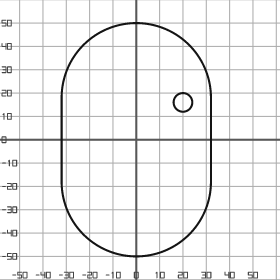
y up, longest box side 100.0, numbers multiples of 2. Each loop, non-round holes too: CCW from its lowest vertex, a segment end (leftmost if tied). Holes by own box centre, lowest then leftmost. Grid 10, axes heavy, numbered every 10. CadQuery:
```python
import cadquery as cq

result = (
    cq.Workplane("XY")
    .moveTo(-32.0, -18.0)
    .threePointArc((0.0, -50.0), (32.0, -18.0))
    .lineTo(32.0, 18.0)
    .threePointArc((0.0, 50.0), (-32.0, 18.0))
    .close()
    .moveTo(20.0, 16.0)
    .circle(4.0)
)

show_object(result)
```